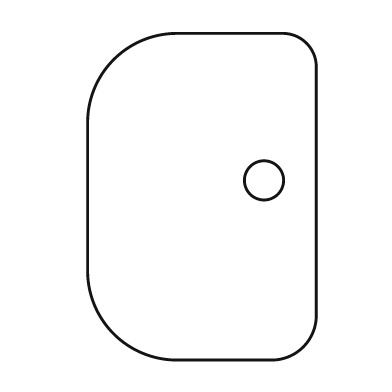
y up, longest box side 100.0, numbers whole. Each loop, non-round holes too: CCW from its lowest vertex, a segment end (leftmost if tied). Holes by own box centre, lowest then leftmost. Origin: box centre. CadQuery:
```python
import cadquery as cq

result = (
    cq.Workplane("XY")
    .moveTo(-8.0, -50.0)
    .lineTo(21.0, -50.0)
    .threePointArc((31.0, -46.0), (35.0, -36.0))
    .lineTo(35.0, 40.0)
    .threePointArc((32.0, 47.0), (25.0, 50.0))
    .lineTo(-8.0, 50.0)
    .threePointArc((-27.0, 42.0), (-35.0, 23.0))
    .lineTo(-35.0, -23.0)
    .threePointArc((-27.0, -42.0), (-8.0, -50.0))
    .close()
    .moveTo(19.0, 5.0)
    .circle(6.0)
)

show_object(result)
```